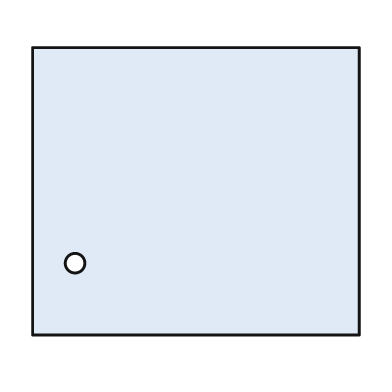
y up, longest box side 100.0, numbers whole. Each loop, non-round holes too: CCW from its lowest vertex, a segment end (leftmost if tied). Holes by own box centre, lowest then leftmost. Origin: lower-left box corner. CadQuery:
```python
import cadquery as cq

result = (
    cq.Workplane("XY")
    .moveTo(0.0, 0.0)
    .lineTo(100.0, 0.0)
    .lineTo(100.0, 88.0)
    .lineTo(0.0, 88.0)
    .close()
    .moveTo(13.0, 22.0)
    .circle(3.0)
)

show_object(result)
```